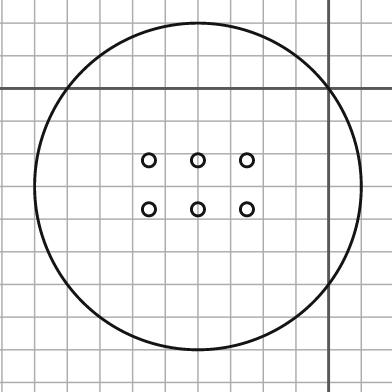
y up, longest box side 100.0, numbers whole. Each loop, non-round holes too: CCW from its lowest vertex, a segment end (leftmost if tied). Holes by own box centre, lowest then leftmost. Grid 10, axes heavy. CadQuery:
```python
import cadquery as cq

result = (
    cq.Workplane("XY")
    .moveTo(-40.0, -30.0)
    .circle(50.0)
    .moveTo(-55.0, -37.0)
    .circle(2.0)
    .moveTo(-40.0, -37.0)
    .circle(2.0)
    .moveTo(-25.0, -37.0)
    .circle(2.0)
    .moveTo(-55.0, -22.0)
    .circle(2.0)
    .moveTo(-40.0, -22.0)
    .circle(2.0)
    .moveTo(-25.0, -22.0)
    .circle(2.0)
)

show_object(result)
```